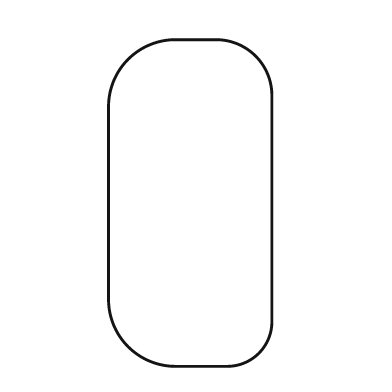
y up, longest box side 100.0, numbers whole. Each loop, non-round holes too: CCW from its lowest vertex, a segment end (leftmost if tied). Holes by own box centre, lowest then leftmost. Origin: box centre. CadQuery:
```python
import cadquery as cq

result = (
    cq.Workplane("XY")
    .moveTo(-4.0, -50.0)
    .lineTo(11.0, -50.0)
    .threePointArc((21.0, -46.0), (25.0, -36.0))
    .lineTo(25.0, 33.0)
    .threePointArc((20.0, 45.0), (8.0, 50.0))
    .lineTo(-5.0, 50.0)
    .threePointArc((-19.0, 44.0), (-25.0, 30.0))
    .lineTo(-25.0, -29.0)
    .threePointArc((-19.0, -44.0), (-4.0, -50.0))
    .close()
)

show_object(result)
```